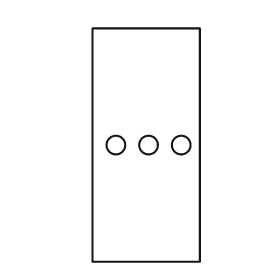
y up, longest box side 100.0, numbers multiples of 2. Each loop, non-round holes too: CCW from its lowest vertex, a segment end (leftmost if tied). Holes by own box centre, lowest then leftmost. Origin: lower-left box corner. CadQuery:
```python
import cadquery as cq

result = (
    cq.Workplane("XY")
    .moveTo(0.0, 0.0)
    .lineTo(46.0, 0.0)
    .lineTo(46.0, 100.0)
    .lineTo(0.0, 100.0)
    .close()
    .moveTo(10.0, 50.0)
    .circle(4.0)
    .moveTo(24.0, 50.0)
    .circle(4.0)
    .moveTo(38.0, 50.0)
    .circle(4.0)
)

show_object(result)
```